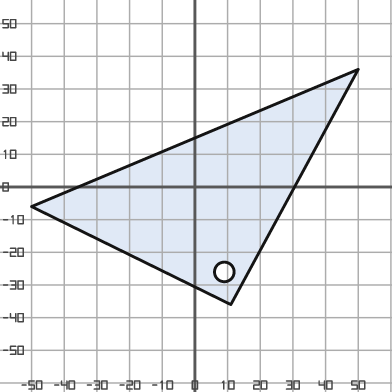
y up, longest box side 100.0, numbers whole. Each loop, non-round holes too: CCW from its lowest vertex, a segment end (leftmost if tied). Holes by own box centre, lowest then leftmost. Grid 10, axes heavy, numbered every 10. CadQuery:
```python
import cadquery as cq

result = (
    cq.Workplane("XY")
    .moveTo(11.0, -36.0)
    .lineTo(50.0, 36.0)
    .lineTo(-50.0, -6.0)
    .close()
    .moveTo(9.0, -26.0)
    .circle(3.0)
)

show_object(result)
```